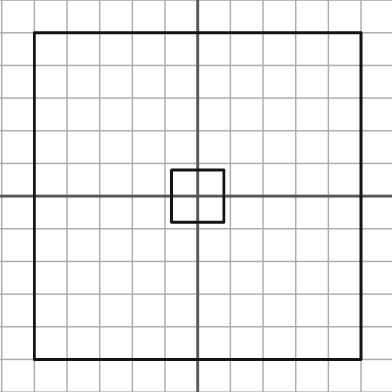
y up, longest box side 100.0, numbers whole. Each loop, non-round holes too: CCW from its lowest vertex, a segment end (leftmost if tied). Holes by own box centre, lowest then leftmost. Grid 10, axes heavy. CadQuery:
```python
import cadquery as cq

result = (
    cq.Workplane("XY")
    .moveTo(-50.0, -50.0)
    .lineTo(50.0, -50.0)
    .lineTo(50.0, 50.0)
    .lineTo(-50.0, 50.0)
    .close()
    .moveTo(-8.0, -8.0)
    .lineTo(8.0, -8.0)
    .lineTo(8.0, 8.0)
    .lineTo(-8.0, 8.0)
    .close()
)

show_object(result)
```